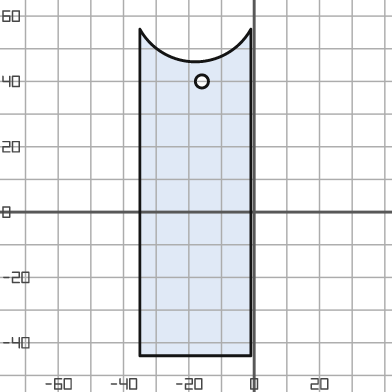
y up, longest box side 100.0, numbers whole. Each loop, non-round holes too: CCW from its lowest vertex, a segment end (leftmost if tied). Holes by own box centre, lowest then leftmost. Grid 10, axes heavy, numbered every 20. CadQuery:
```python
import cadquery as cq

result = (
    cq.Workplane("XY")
    .moveTo(-35.0, -44.0)
    .lineTo(-1.0, -44.0)
    .lineTo(-1.0, 56.0)
    .threePointArc((-18.0, 46.0), (-35.0, 56.0))
    .close()
    .moveTo(-16.0, 40.0)
    .circle(2.0)
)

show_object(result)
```